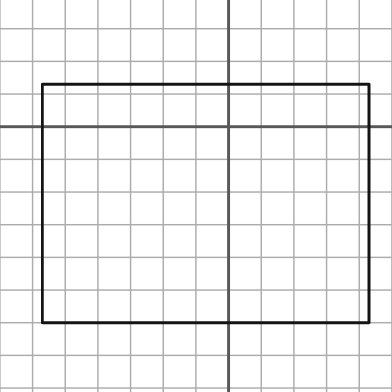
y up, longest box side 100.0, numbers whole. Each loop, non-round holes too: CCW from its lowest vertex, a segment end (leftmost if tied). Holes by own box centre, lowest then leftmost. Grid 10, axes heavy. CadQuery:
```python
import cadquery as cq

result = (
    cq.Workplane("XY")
    .moveTo(-57.0, -60.0)
    .lineTo(43.0, -60.0)
    .lineTo(43.0, 13.0)
    .lineTo(-57.0, 13.0)
    .close()
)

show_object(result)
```